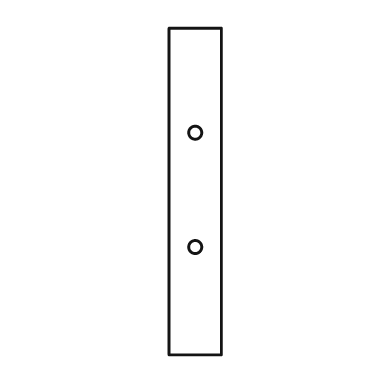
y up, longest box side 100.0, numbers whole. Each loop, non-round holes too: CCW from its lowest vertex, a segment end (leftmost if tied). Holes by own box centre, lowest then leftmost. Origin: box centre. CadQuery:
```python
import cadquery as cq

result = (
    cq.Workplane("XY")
    .moveTo(-8.0, -50.0)
    .lineTo(8.0, -50.0)
    .lineTo(8.0, 50.0)
    .lineTo(-8.0, 50.0)
    .close()
    .moveTo(0.0, -17.0)
    .circle(2.0)
    .moveTo(0.0, 18.0)
    .circle(2.0)
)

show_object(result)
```